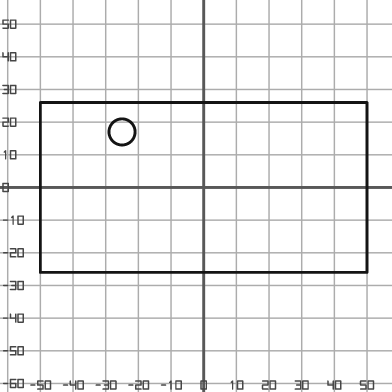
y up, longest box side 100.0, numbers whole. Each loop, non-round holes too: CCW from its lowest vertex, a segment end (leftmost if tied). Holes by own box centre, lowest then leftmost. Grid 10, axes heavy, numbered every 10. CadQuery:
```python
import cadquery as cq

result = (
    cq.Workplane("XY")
    .moveTo(-50.0, -26.0)
    .lineTo(50.0, -26.0)
    .lineTo(50.0, 26.0)
    .lineTo(-50.0, 26.0)
    .close()
    .moveTo(-25.0, 17.0)
    .circle(4.0)
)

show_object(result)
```